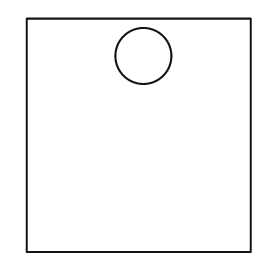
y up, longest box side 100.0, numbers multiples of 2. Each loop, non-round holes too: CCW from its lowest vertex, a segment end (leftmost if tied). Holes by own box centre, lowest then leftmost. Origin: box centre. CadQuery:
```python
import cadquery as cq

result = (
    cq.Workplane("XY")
    .moveTo(-48.0, -50.0)
    .lineTo(48.0, -50.0)
    .lineTo(48.0, 50.0)
    .lineTo(-48.0, 50.0)
    .close()
    .moveTo(2.0, 34.0)
    .circle(12.0)
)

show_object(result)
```